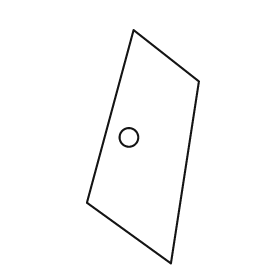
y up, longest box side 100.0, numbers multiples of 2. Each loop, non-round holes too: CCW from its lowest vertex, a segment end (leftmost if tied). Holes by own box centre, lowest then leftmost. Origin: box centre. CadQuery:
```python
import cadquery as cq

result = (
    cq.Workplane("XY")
    .moveTo(12.0, -50.0)
    .lineTo(24.0, 28.0)
    .lineTo(-4.0, 50.0)
    .lineTo(-24.0, -24.0)
    .close()
    .moveTo(-6.0, 4.0)
    .circle(4.0)
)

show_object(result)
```